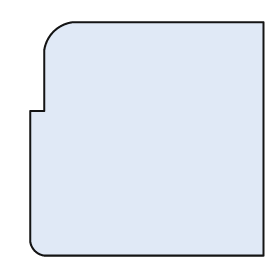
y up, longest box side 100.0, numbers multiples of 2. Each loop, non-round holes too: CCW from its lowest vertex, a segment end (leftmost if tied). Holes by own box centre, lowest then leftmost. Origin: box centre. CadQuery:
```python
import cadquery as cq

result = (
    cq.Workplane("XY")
    .moveTo(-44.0, -50.0)
    .lineTo(50.0, -50.0)
    .lineTo(50.0, 50.0)
    .lineTo(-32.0, 50.0)
    .threePointArc((-40.0, 46.0), (-44.0, 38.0))
    .lineTo(-44.0, 12.0)
    .lineTo(-50.0, 12.0)
    .lineTo(-50.0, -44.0)
    .threePointArc((-48.0, -48.0), (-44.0, -50.0))
    .close()
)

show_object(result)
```